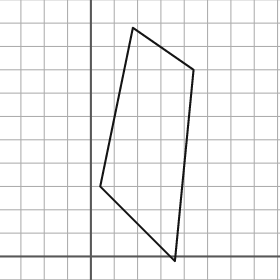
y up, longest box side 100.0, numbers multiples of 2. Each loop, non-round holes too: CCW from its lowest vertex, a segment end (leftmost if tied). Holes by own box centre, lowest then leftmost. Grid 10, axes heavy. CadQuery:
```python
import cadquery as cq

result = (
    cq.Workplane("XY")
    .moveTo(36.0, -2.0)
    .lineTo(44.0, 80.0)
    .lineTo(18.0, 98.0)
    .lineTo(4.0, 30.0)
    .close()
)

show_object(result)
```